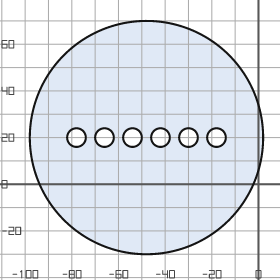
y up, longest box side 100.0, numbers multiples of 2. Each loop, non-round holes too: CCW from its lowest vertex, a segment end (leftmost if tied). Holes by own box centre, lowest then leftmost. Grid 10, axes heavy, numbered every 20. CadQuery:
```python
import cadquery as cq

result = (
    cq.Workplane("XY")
    .moveTo(-48.0, 20.0)
    .circle(50.0)
    .moveTo(-78.0, 20.0)
    .circle(4.0)
    .moveTo(-66.0, 20.0)
    .circle(4.0)
    .moveTo(-54.0, 20.0)
    .circle(4.0)
    .moveTo(-42.0, 20.0)
    .circle(4.0)
    .moveTo(-30.0, 20.0)
    .circle(4.0)
    .moveTo(-18.0, 20.0)
    .circle(4.0)
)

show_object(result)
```